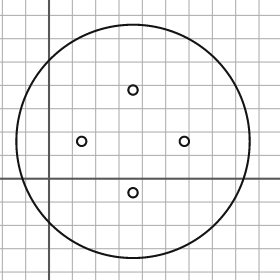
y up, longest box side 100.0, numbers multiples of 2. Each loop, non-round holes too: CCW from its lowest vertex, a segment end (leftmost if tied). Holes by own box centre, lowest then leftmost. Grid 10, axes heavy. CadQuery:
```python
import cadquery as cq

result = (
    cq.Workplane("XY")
    .moveTo(36.0, 16.0)
    .circle(50.0)
    .moveTo(36.0, -6.0)
    .circle(2.0)
    .moveTo(14.0, 16.0)
    .circle(2.0)
    .moveTo(58.0, 16.0)
    .circle(2.0)
    .moveTo(36.0, 38.0)
    .circle(2.0)
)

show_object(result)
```